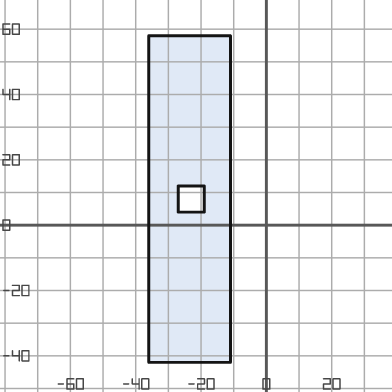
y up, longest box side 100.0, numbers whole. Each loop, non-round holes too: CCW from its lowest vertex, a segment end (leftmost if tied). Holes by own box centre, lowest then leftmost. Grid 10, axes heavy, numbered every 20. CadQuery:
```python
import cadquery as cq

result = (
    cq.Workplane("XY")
    .moveTo(-36.0, -42.0)
    .lineTo(-11.0, -42.0)
    .lineTo(-11.0, 58.0)
    .lineTo(-36.0, 58.0)
    .close()
    .moveTo(-27.0, 4.0)
    .lineTo(-19.0, 4.0)
    .lineTo(-19.0, 12.0)
    .lineTo(-27.0, 12.0)
    .close()
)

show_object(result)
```